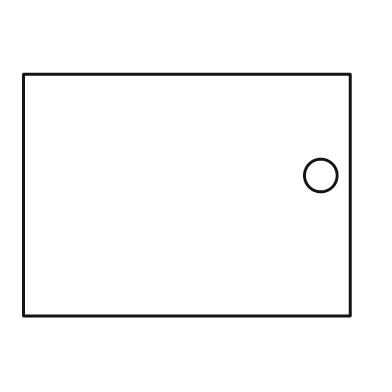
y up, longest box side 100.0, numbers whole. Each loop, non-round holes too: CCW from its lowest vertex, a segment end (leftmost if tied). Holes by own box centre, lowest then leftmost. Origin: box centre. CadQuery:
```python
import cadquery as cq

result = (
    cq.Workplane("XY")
    .moveTo(-50.0, -37.0)
    .lineTo(50.0, -37.0)
    .lineTo(50.0, 37.0)
    .lineTo(-50.0, 37.0)
    .close()
    .moveTo(41.0, 6.0)
    .circle(5.0)
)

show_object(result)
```